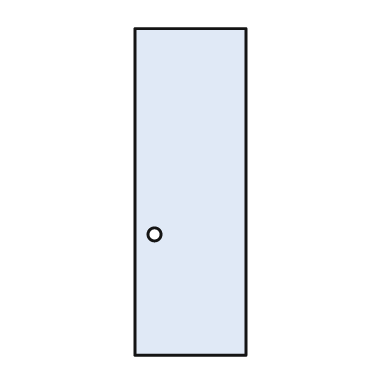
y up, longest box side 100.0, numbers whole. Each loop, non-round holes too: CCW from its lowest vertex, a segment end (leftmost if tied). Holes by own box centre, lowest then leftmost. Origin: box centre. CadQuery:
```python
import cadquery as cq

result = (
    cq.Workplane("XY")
    .moveTo(-17.0, -50.0)
    .lineTo(17.0, -50.0)
    .lineTo(17.0, 50.0)
    .lineTo(-17.0, 50.0)
    .close()
    .moveTo(-11.0, -13.0)
    .circle(2.0)
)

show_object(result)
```